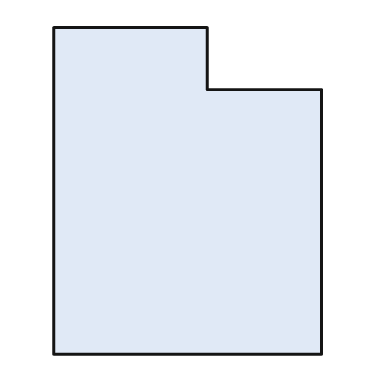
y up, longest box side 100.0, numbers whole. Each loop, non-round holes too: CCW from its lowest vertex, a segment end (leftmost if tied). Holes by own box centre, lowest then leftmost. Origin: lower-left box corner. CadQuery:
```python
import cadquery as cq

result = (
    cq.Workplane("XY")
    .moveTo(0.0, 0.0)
    .lineTo(82.0, 0.0)
    .lineTo(82.0, 81.0)
    .lineTo(47.0, 81.0)
    .lineTo(47.0, 100.0)
    .lineTo(0.0, 100.0)
    .close()
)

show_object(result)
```